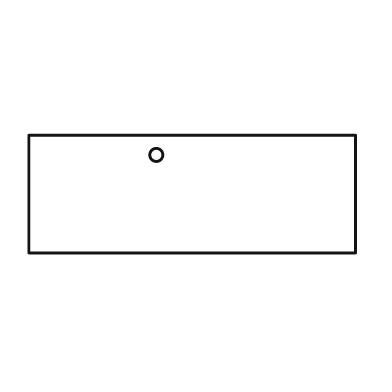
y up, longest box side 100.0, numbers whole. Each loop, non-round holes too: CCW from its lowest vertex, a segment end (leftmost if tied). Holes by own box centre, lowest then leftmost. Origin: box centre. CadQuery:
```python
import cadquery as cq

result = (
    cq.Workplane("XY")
    .moveTo(-50.0, -18.0)
    .lineTo(50.0, -18.0)
    .lineTo(50.0, 18.0)
    .lineTo(-50.0, 18.0)
    .close()
    .moveTo(-11.0, 12.0)
    .circle(2.0)
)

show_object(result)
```